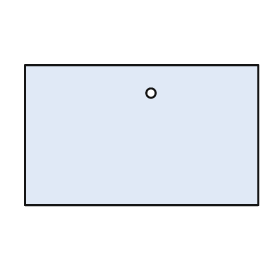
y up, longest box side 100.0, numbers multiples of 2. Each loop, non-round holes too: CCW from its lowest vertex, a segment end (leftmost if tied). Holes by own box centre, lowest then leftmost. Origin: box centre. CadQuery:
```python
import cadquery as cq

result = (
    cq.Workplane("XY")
    .moveTo(-50.0, -30.0)
    .lineTo(50.0, -30.0)
    .lineTo(50.0, 30.0)
    .lineTo(-50.0, 30.0)
    .close()
    .moveTo(4.0, 18.0)
    .circle(2.0)
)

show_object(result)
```